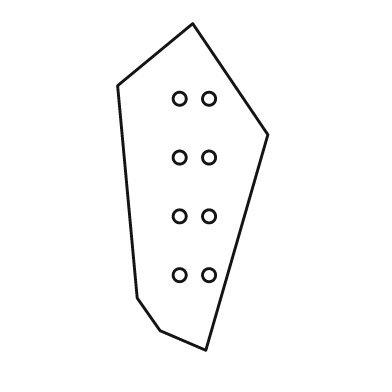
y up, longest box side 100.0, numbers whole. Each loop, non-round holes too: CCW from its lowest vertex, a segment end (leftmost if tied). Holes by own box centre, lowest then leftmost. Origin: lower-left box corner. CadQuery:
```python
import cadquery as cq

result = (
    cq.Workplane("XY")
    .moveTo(27.0, 0.0)
    .lineTo(46.0, 66.0)
    .lineTo(23.0, 100.0)
    .lineTo(0.0, 81.0)
    .lineTo(6.0, 16.0)
    .lineTo(13.0, 6.0)
    .close()
    .moveTo(19.0, 23.0)
    .circle(2.0)
    .moveTo(28.0, 23.0)
    .circle(2.0)
    .moveTo(19.0, 41.0)
    .circle(2.0)
    .moveTo(28.0, 41.0)
    .circle(2.0)
    .moveTo(19.0, 59.0)
    .circle(2.0)
    .moveTo(28.0, 59.0)
    .circle(2.0)
    .moveTo(19.0, 77.0)
    .circle(2.0)
    .moveTo(28.0, 77.0)
    .circle(2.0)
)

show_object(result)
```